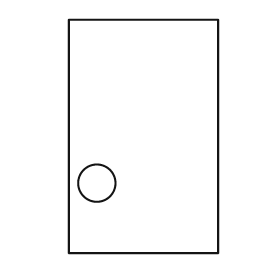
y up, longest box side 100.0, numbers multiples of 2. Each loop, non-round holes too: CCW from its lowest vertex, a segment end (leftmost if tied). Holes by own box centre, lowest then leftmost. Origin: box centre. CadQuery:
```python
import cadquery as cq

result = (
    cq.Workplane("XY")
    .moveTo(-32.0, -50.0)
    .lineTo(32.0, -50.0)
    .lineTo(32.0, 50.0)
    .lineTo(-32.0, 50.0)
    .close()
    .moveTo(-20.0, -20.0)
    .circle(8.0)
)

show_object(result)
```